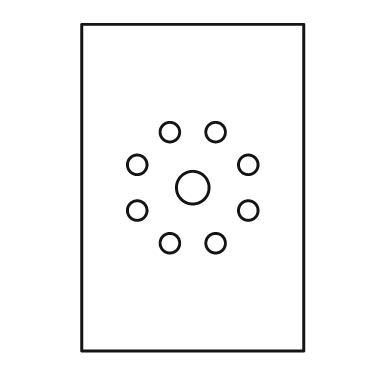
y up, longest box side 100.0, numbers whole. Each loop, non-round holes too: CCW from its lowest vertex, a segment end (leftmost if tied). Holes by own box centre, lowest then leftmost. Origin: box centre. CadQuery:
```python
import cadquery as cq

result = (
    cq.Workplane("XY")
    .moveTo(-34.0, -50.0)
    .lineTo(34.0, -50.0)
    .lineTo(34.0, 50.0)
    .lineTo(-34.0, 50.0)
    .close()
    .moveTo(-7.0, -17.0)
    .circle(3.0)
    .moveTo(7.0, -17.0)
    .circle(3.0)
    .moveTo(-17.0, -7.0)
    .circle(3.0)
    .moveTo(17.0, -7.0)
    .circle(3.0)
    .moveTo(0.0, 0.0)
    .circle(5.0)
    .moveTo(-17.0, 7.0)
    .circle(3.0)
    .moveTo(17.0, 7.0)
    .circle(3.0)
    .moveTo(-7.0, 17.0)
    .circle(3.0)
    .moveTo(7.0, 17.0)
    .circle(3.0)
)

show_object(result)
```